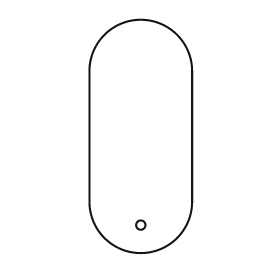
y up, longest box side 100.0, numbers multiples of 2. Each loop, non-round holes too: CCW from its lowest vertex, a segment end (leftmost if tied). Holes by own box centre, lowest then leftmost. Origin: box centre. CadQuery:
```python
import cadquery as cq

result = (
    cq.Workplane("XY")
    .moveTo(-22.0, -28.0)
    .threePointArc((0.0, -50.0), (22.0, -28.0))
    .lineTo(22.0, 28.0)
    .threePointArc((0.0, 50.0), (-22.0, 28.0))
    .close()
    .moveTo(0.0, -38.0)
    .circle(2.0)
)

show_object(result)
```